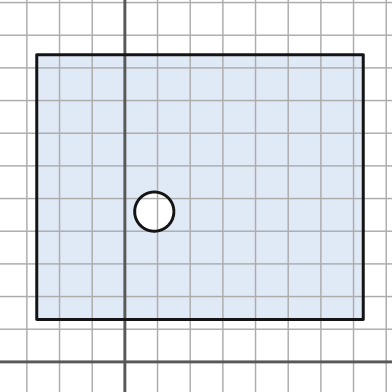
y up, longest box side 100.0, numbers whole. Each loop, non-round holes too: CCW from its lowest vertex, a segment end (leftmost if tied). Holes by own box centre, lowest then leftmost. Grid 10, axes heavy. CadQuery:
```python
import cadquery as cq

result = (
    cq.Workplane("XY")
    .moveTo(-27.0, 13.0)
    .lineTo(73.0, 13.0)
    .lineTo(73.0, 94.0)
    .lineTo(-27.0, 94.0)
    .close()
    .moveTo(9.0, 46.0)
    .circle(6.0)
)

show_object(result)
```